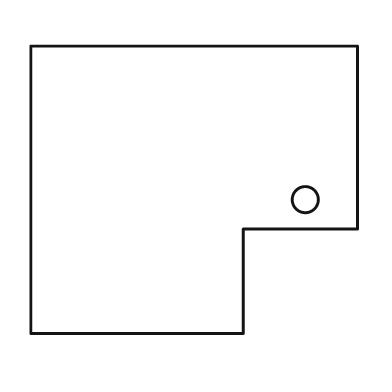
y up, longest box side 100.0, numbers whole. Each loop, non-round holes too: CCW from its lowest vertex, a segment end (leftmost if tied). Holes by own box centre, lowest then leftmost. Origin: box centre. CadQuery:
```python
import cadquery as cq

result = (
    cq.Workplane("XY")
    .moveTo(-50.0, -44.0)
    .lineTo(15.0, -44.0)
    .lineTo(15.0, -12.0)
    .lineTo(50.0, -12.0)
    .lineTo(50.0, 44.0)
    .lineTo(-50.0, 44.0)
    .close()
    .moveTo(34.0, -3.0)
    .circle(4.0)
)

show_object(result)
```